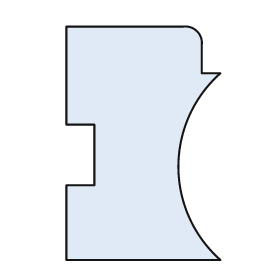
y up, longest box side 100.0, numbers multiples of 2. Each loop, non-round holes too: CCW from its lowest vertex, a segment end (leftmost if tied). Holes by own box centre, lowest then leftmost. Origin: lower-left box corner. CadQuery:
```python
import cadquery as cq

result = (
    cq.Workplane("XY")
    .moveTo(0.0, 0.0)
    .lineTo(66.0, 0.0)
    .threePointArc((48.0, 40.0), (66.0, 80.0))
    .lineTo(58.0, 80.0)
    .lineTo(58.0, 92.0)
    .threePointArc((56.0, 98.0), (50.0, 100.0))
    .lineTo(0.0, 100.0)
    .lineTo(0.0, 58.0)
    .lineTo(12.0, 58.0)
    .lineTo(12.0, 32.0)
    .lineTo(0.0, 32.0)
    .close()
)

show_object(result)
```